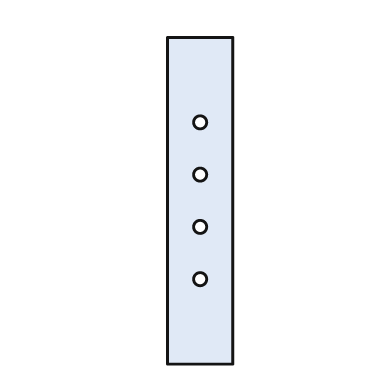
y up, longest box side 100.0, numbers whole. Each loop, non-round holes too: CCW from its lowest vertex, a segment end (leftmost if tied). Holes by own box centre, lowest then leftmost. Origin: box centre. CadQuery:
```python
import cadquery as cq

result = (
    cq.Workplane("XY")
    .moveTo(-10.0, -50.0)
    .lineTo(10.0, -50.0)
    .lineTo(10.0, 50.0)
    .lineTo(-10.0, 50.0)
    .close()
    .moveTo(0.0, -24.0)
    .circle(2.0)
    .moveTo(0.0, -8.0)
    .circle(2.0)
    .moveTo(0.0, 8.0)
    .circle(2.0)
    .moveTo(0.0, 24.0)
    .circle(2.0)
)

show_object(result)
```